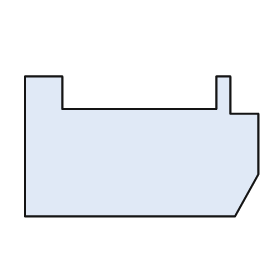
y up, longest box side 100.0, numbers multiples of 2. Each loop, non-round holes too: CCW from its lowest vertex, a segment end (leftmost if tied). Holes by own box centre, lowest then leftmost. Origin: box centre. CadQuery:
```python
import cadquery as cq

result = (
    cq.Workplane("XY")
    .moveTo(-50.0, -30.0)
    .lineTo(40.0, -30.0)
    .lineTo(50.0, -12.0)
    .lineTo(50.0, 14.0)
    .lineTo(38.0, 14.0)
    .lineTo(38.0, 30.0)
    .lineTo(32.0, 30.0)
    .lineTo(32.0, 16.0)
    .lineTo(-34.0, 16.0)
    .lineTo(-34.0, 30.0)
    .lineTo(-50.0, 30.0)
    .close()
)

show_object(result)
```